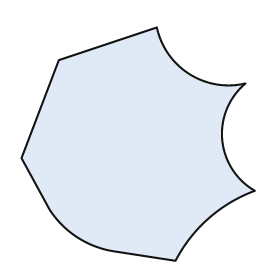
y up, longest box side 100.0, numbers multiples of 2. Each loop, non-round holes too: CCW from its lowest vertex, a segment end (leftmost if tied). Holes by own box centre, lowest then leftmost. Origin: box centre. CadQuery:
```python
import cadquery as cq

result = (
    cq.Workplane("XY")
    .moveTo(16.0, -50.0)
    .threePointArc((30.0, -32.0), (50.0, -20.0))
    .threePointArc((36.0, 2.0), (46.0, 26.0))
    .threePointArc((22.0, 30.0), (8.0, 50.0))
    .lineTo(-34.0, 36.0)
    .lineTo(-50.0, -6.0)
    .lineTo(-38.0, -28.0)
    .threePointArc((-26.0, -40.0), (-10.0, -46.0))
    .close()
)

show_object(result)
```